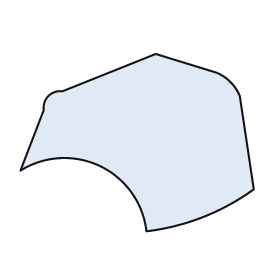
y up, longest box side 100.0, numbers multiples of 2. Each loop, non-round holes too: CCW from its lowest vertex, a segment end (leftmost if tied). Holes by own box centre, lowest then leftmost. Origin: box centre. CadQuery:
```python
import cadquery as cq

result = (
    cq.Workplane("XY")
    .moveTo(4.0, -38.0)
    .threePointArc((28.0, -32.0), (50.0, -20.0))
    .lineTo(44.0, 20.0)
    .threePointArc((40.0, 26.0), (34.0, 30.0))
    .lineTo(8.0, 38.0)
    .lineTo(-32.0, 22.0)
    .threePointArc((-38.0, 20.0), (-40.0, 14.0))
    .lineTo(-50.0, -12.0)
    .threePointArc((-16.0, -10.0), (4.0, -38.0))
    .close()
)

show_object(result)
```